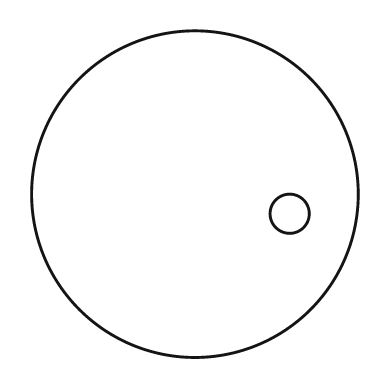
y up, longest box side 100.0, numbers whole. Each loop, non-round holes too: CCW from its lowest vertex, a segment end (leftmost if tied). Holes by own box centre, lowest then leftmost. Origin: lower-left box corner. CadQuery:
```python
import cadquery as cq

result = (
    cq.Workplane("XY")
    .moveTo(50.0, 50.0)
    .circle(50.0)
    .moveTo(79.0, 44.0)
    .circle(6.0)
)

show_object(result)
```